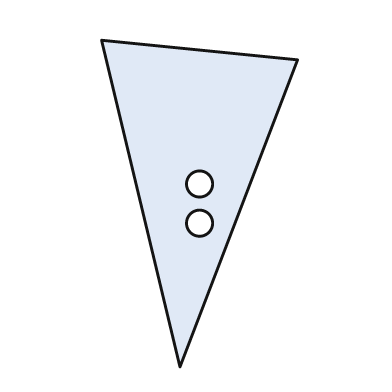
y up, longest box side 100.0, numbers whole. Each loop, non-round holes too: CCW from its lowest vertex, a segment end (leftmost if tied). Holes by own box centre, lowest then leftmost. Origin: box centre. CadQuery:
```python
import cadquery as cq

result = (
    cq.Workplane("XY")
    .moveTo(-6.0, -50.0)
    .lineTo(30.0, 44.0)
    .lineTo(-30.0, 50.0)
    .close()
    .moveTo(0.0, -6.0)
    .circle(4.0)
    .moveTo(0.0, 6.0)
    .circle(4.0)
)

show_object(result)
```